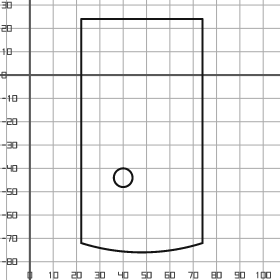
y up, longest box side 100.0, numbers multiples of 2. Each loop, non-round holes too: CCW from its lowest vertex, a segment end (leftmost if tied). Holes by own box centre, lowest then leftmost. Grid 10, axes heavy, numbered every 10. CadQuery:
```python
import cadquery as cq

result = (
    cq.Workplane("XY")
    .moveTo(22.0, -72.0)
    .threePointArc((48.0, -76.0), (74.0, -72.0))
    .lineTo(74.0, 24.0)
    .lineTo(22.0, 24.0)
    .close()
    .moveTo(40.0, -44.0)
    .circle(4.0)
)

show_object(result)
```